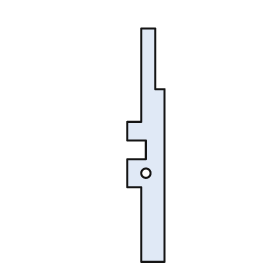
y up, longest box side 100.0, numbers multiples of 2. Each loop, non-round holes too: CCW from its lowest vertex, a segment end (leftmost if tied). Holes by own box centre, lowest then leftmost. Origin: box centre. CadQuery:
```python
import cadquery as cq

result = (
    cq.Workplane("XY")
    .moveTo(-2.0, -50.0)
    .lineTo(8.0, -50.0)
    .lineTo(8.0, 24.0)
    .lineTo(4.0, 24.0)
    .lineTo(4.0, 50.0)
    .lineTo(-2.0, 50.0)
    .lineTo(-2.0, 10.0)
    .lineTo(-8.0, 10.0)
    .lineTo(-8.0, 2.0)
    .lineTo(0.0, 2.0)
    .lineTo(0.0, -6.0)
    .lineTo(-8.0, -6.0)
    .lineTo(-8.0, -18.0)
    .lineTo(-2.0, -18.0)
    .close()
    .moveTo(0.0, -12.0)
    .circle(2.0)
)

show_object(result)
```